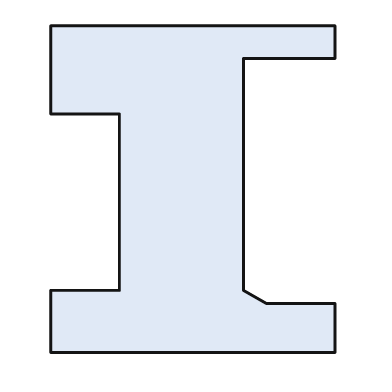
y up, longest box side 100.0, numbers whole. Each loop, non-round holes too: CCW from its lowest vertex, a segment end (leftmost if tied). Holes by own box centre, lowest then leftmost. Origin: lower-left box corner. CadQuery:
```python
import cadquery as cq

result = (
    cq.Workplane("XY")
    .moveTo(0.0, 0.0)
    .lineTo(87.0, 0.0)
    .lineTo(87.0, 15.0)
    .lineTo(66.0, 15.0)
    .lineTo(59.0, 19.0)
    .lineTo(59.0, 90.0)
    .lineTo(87.0, 90.0)
    .lineTo(87.0, 100.0)
    .lineTo(0.0, 100.0)
    .lineTo(0.0, 73.0)
    .lineTo(21.0, 73.0)
    .lineTo(21.0, 19.0)
    .lineTo(0.0, 19.0)
    .close()
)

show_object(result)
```